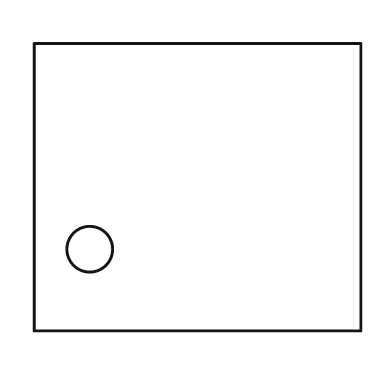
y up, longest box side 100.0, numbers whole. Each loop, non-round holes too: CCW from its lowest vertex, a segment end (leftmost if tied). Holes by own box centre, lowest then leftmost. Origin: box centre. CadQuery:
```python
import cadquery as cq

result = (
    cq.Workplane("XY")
    .moveTo(-50.0, -44.0)
    .lineTo(50.0, -44.0)
    .lineTo(50.0, 44.0)
    .lineTo(-50.0, 44.0)
    .close()
    .moveTo(-33.0, -19.0)
    .circle(7.0)
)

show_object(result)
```